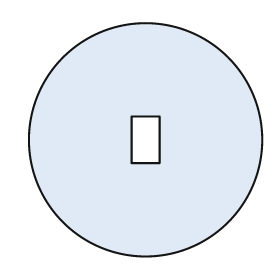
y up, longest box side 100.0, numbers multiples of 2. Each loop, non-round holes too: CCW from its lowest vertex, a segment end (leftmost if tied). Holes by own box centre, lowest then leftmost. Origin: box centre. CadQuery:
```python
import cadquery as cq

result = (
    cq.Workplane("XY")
    .moveTo(0.0, 0.0)
    .circle(50.0)
    .moveTo(-6.0, -10.0)
    .lineTo(6.0, -10.0)
    .lineTo(6.0, 10.0)
    .lineTo(-6.0, 10.0)
    .close()
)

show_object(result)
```